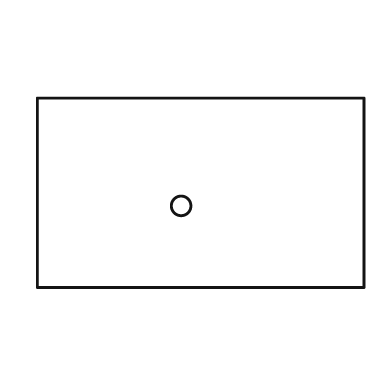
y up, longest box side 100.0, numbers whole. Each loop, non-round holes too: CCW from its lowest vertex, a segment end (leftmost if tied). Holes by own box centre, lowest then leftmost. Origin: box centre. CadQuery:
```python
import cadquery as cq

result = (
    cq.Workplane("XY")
    .moveTo(-50.0, -29.0)
    .lineTo(50.0, -29.0)
    .lineTo(50.0, 29.0)
    .lineTo(-50.0, 29.0)
    .close()
    .moveTo(-6.0, -4.0)
    .circle(3.0)
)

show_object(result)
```